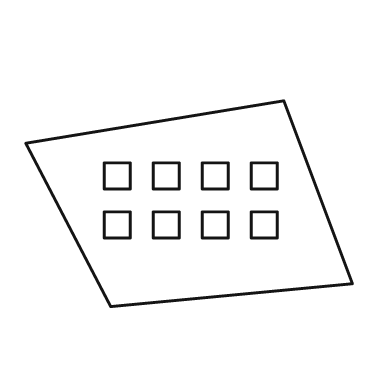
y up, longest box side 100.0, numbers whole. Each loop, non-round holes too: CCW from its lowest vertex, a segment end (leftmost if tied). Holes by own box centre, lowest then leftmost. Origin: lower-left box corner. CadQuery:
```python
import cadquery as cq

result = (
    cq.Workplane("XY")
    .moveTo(26.0, 0.0)
    .lineTo(100.0, 7.0)
    .lineTo(79.0, 63.0)
    .lineTo(0.0, 50.0)
    .close()
    .moveTo(24.0, 21.0)
    .lineTo(32.0, 21.0)
    .lineTo(32.0, 29.0)
    .lineTo(24.0, 29.0)
    .close()
    .moveTo(39.0, 21.0)
    .lineTo(47.0, 21.0)
    .lineTo(47.0, 29.0)
    .lineTo(39.0, 29.0)
    .close()
    .moveTo(54.0, 21.0)
    .lineTo(62.0, 21.0)
    .lineTo(62.0, 29.0)
    .lineTo(54.0, 29.0)
    .close()
    .moveTo(69.0, 21.0)
    .lineTo(77.0, 21.0)
    .lineTo(77.0, 29.0)
    .lineTo(69.0, 29.0)
    .close()
    .moveTo(24.0, 36.0)
    .lineTo(32.0, 36.0)
    .lineTo(32.0, 44.0)
    .lineTo(24.0, 44.0)
    .close()
    .moveTo(39.0, 36.0)
    .lineTo(47.0, 36.0)
    .lineTo(47.0, 44.0)
    .lineTo(39.0, 44.0)
    .close()
    .moveTo(54.0, 36.0)
    .lineTo(62.0, 36.0)
    .lineTo(62.0, 44.0)
    .lineTo(54.0, 44.0)
    .close()
    .moveTo(69.0, 36.0)
    .lineTo(77.0, 36.0)
    .lineTo(77.0, 44.0)
    .lineTo(69.0, 44.0)
    .close()
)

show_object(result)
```